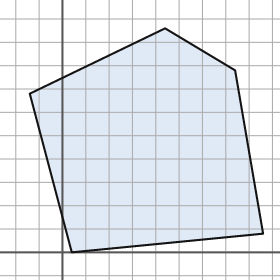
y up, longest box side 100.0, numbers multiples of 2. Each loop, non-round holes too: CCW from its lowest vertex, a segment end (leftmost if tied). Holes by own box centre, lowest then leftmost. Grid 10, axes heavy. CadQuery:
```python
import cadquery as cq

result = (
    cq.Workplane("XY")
    .moveTo(4.0, 0.0)
    .lineTo(86.0, 8.0)
    .lineTo(74.0, 78.0)
    .lineTo(44.0, 96.0)
    .lineTo(-14.0, 68.0)
    .close()
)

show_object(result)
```